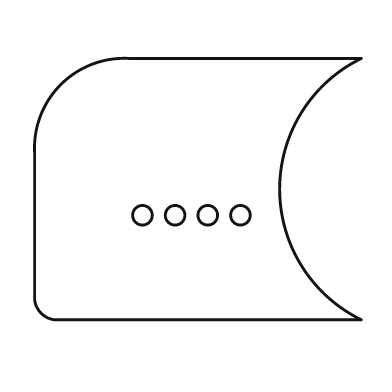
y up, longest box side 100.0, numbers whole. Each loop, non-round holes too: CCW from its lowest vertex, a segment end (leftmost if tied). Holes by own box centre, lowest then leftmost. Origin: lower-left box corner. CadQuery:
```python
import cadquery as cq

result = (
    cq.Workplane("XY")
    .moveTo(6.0, 0.0)
    .lineTo(100.0, 0.0)
    .threePointArc((75.0, 40.0), (100.0, 80.0))
    .lineTo(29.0, 80.0)
    .threePointArc((8.0, 72.0), (0.0, 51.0))
    .lineTo(0.0, 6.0)
    .threePointArc((2.0, 2.0), (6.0, 0.0))
    .close()
    .moveTo(33.0, 32.0)
    .circle(3.0)
    .moveTo(43.0, 32.0)
    .circle(3.0)
    .moveTo(53.0, 32.0)
    .circle(3.0)
    .moveTo(63.0, 32.0)
    .circle(3.0)
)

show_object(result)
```